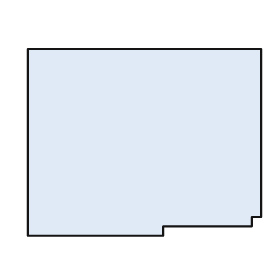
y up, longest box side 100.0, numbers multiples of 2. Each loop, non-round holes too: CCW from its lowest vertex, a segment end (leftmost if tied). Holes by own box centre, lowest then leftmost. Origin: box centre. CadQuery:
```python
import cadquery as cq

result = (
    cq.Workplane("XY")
    .moveTo(-50.0, -40.0)
    .lineTo(8.0, -40.0)
    .lineTo(8.0, -36.0)
    .lineTo(46.0, -36.0)
    .lineTo(46.0, -32.0)
    .lineTo(50.0, -32.0)
    .lineTo(50.0, 40.0)
    .lineTo(-50.0, 40.0)
    .close()
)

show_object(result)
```